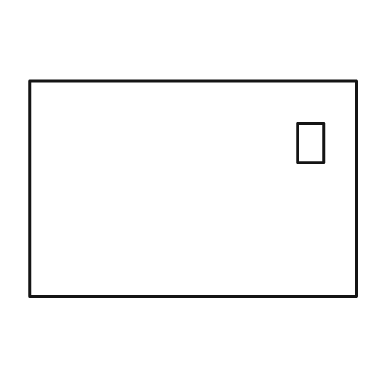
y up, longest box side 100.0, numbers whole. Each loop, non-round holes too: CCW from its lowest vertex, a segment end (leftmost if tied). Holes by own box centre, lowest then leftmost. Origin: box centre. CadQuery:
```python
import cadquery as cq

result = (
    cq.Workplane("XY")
    .moveTo(-50.0, -33.0)
    .lineTo(50.0, -33.0)
    .lineTo(50.0, 33.0)
    .lineTo(-50.0, 33.0)
    .close()
    .moveTo(32.0, 8.0)
    .lineTo(40.0, 8.0)
    .lineTo(40.0, 20.0)
    .lineTo(32.0, 20.0)
    .close()
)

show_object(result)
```